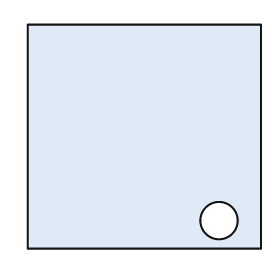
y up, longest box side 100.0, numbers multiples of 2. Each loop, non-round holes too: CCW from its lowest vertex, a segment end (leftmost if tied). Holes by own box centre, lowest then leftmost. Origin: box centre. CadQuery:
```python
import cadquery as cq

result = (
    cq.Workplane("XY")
    .moveTo(-50.0, -48.0)
    .lineTo(50.0, -48.0)
    .lineTo(50.0, 48.0)
    .lineTo(-50.0, 48.0)
    .close()
    .moveTo(32.0, -36.0)
    .circle(8.0)
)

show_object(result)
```